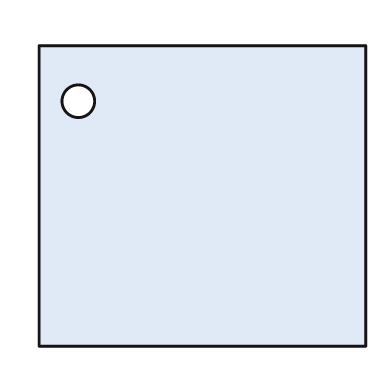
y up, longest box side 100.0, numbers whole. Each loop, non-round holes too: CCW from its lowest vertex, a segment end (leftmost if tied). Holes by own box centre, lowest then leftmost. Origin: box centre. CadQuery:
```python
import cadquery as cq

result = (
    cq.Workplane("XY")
    .moveTo(-50.0, -46.0)
    .lineTo(50.0, -46.0)
    .lineTo(50.0, 46.0)
    .lineTo(-50.0, 46.0)
    .close()
    .moveTo(-38.0, 29.0)
    .circle(5.0)
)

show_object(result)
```